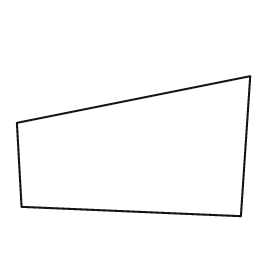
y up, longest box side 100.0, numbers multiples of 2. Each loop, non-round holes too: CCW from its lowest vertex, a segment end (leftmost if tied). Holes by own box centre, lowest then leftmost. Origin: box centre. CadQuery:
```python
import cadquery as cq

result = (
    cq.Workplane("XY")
    .moveTo(46.0, -30.0)
    .lineTo(50.0, 30.0)
    .lineTo(-50.0, 10.0)
    .lineTo(-48.0, -26.0)
    .close()
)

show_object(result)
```